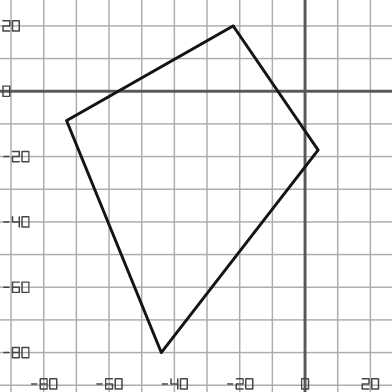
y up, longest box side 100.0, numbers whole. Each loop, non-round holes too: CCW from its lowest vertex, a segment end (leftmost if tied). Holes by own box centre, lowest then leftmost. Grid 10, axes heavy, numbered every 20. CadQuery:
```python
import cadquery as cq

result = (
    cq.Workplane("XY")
    .moveTo(-44.0, -80.0)
    .lineTo(4.0, -18.0)
    .lineTo(-22.0, 20.0)
    .lineTo(-73.0, -9.0)
    .close()
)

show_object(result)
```